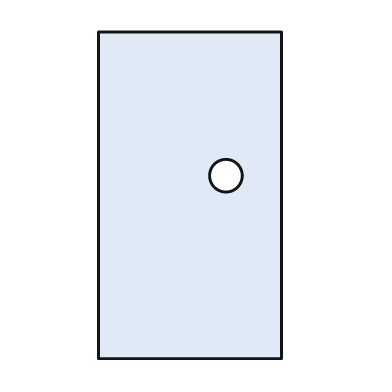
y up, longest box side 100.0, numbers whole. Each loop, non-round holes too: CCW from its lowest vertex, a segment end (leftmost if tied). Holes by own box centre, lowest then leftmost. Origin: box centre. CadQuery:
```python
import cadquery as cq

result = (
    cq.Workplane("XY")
    .moveTo(-28.0, -50.0)
    .lineTo(28.0, -50.0)
    .lineTo(28.0, 50.0)
    .lineTo(-28.0, 50.0)
    .close()
    .moveTo(11.0, 6.0)
    .circle(5.0)
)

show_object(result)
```